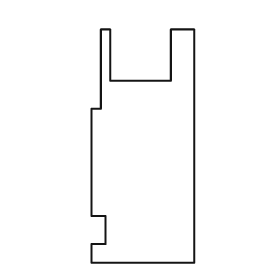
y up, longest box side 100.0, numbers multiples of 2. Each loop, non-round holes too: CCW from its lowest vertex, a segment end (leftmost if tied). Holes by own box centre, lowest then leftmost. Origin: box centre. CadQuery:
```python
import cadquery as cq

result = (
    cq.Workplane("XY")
    .moveTo(-22.0, -50.0)
    .lineTo(22.0, -50.0)
    .lineTo(22.0, 50.0)
    .lineTo(12.0, 50.0)
    .lineTo(12.0, 28.0)
    .lineTo(-14.0, 28.0)
    .lineTo(-14.0, 50.0)
    .lineTo(-18.0, 50.0)
    .lineTo(-18.0, 16.0)
    .lineTo(-22.0, 16.0)
    .lineTo(-22.0, -30.0)
    .lineTo(-16.0, -30.0)
    .lineTo(-16.0, -42.0)
    .lineTo(-22.0, -42.0)
    .close()
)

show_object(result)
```